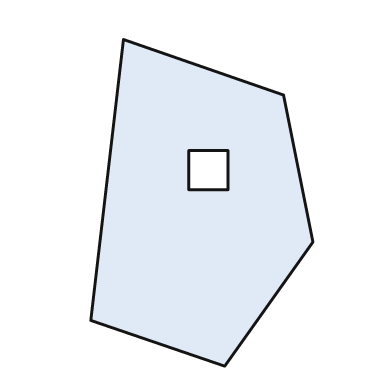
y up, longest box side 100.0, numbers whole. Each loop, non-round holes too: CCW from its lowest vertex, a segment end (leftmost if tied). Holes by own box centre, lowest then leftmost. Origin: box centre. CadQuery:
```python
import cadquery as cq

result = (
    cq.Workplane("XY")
    .moveTo(7.0, -50.0)
    .lineTo(34.0, -12.0)
    .lineTo(25.0, 33.0)
    .lineTo(-24.0, 50.0)
    .lineTo(-34.0, -36.0)
    .close()
    .moveTo(-4.0, 4.0)
    .lineTo(8.0, 4.0)
    .lineTo(8.0, 16.0)
    .lineTo(-4.0, 16.0)
    .close()
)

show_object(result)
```